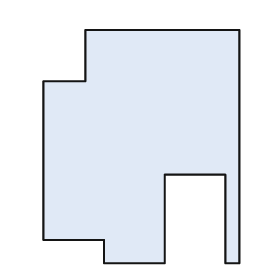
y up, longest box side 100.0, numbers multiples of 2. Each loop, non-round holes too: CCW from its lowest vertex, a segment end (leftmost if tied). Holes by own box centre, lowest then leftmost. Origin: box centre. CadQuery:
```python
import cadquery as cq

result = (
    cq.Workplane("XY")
    .moveTo(-16.0, -50.0)
    .lineTo(10.0, -50.0)
    .lineTo(10.0, -12.0)
    .lineTo(36.0, -12.0)
    .lineTo(36.0, -50.0)
    .lineTo(42.0, -50.0)
    .lineTo(42.0, 50.0)
    .lineTo(-24.0, 50.0)
    .lineTo(-24.0, 28.0)
    .lineTo(-42.0, 28.0)
    .lineTo(-42.0, -40.0)
    .lineTo(-16.0, -40.0)
    .close()
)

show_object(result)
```